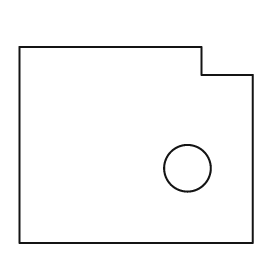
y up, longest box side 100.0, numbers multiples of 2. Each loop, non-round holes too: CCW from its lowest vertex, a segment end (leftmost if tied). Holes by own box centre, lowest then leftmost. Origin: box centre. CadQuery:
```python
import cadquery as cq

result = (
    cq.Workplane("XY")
    .moveTo(-50.0, -42.0)
    .lineTo(50.0, -42.0)
    .lineTo(50.0, 30.0)
    .lineTo(28.0, 30.0)
    .lineTo(28.0, 42.0)
    .lineTo(-50.0, 42.0)
    .close()
    .moveTo(22.0, -10.0)
    .circle(10.0)
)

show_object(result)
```